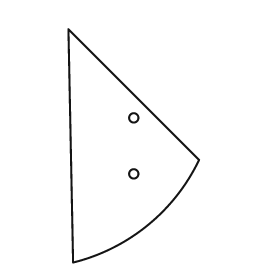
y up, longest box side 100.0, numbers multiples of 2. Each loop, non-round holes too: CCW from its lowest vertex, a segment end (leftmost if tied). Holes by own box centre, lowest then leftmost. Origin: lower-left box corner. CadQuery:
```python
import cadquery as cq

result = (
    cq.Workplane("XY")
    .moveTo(2.0, 0.0)
    .threePointArc((34.0, 16.0), (56.0, 44.0))
    .lineTo(0.0, 100.0)
    .close()
    .moveTo(28.0, 38.0)
    .circle(2.0)
    .moveTo(28.0, 62.0)
    .circle(2.0)
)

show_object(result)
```